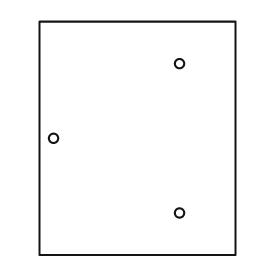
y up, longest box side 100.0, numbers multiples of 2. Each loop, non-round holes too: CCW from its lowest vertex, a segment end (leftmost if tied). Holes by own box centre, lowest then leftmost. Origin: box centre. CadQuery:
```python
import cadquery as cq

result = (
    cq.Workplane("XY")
    .moveTo(-42.0, -50.0)
    .lineTo(42.0, -50.0)
    .lineTo(42.0, 50.0)
    .lineTo(-42.0, 50.0)
    .close()
    .moveTo(18.0, -32.0)
    .circle(2.0)
    .moveTo(-36.0, 0.0)
    .circle(2.0)
    .moveTo(18.0, 32.0)
    .circle(2.0)
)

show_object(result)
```